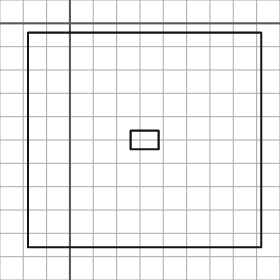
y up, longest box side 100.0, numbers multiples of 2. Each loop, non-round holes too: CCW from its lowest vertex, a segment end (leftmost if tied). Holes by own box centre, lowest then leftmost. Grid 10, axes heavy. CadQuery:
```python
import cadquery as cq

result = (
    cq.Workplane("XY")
    .moveTo(-18.0, -96.0)
    .lineTo(82.0, -96.0)
    .lineTo(82.0, -4.0)
    .lineTo(-18.0, -4.0)
    .close()
    .moveTo(26.0, -54.0)
    .lineTo(38.0, -54.0)
    .lineTo(38.0, -46.0)
    .lineTo(26.0, -46.0)
    .close()
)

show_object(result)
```